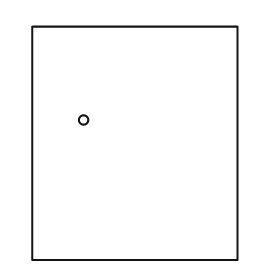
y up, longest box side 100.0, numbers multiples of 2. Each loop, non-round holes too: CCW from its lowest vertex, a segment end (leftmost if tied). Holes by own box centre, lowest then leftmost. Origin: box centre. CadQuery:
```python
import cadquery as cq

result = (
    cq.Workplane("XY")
    .moveTo(-44.0, -50.0)
    .lineTo(44.0, -50.0)
    .lineTo(44.0, 50.0)
    .lineTo(-44.0, 50.0)
    .close()
    .moveTo(-22.0, 10.0)
    .circle(2.0)
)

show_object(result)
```